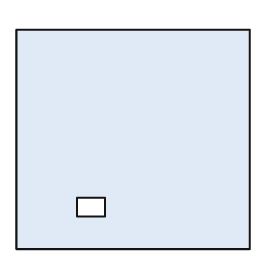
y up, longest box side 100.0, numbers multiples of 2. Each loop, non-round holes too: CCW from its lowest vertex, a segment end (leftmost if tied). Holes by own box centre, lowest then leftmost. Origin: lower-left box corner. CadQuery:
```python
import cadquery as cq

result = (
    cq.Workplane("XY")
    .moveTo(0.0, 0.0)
    .lineTo(100.0, 0.0)
    .lineTo(100.0, 94.0)
    .lineTo(0.0, 94.0)
    .close()
    .moveTo(26.0, 14.0)
    .lineTo(38.0, 14.0)
    .lineTo(38.0, 22.0)
    .lineTo(26.0, 22.0)
    .close()
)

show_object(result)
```